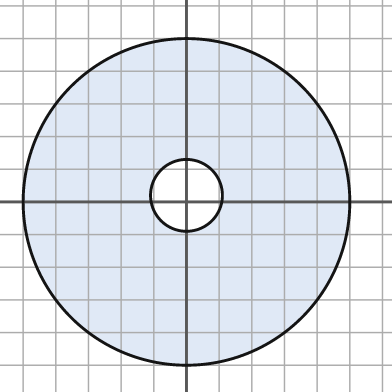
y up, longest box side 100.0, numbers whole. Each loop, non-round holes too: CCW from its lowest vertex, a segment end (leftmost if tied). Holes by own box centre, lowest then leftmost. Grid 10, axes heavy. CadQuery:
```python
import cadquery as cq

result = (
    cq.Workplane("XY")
    .moveTo(0.0, 0.0)
    .circle(50.0)
    .moveTo(0.0, 2.0)
    .circle(11.0)
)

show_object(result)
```